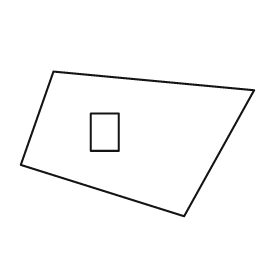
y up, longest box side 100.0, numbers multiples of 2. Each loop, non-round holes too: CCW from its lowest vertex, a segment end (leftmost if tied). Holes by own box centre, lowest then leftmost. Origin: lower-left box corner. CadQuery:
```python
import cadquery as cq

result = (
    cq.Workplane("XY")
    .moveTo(70.0, 0.0)
    .lineTo(100.0, 54.0)
    .lineTo(14.0, 62.0)
    .lineTo(0.0, 22.0)
    .close()
    .moveTo(30.0, 28.0)
    .lineTo(42.0, 28.0)
    .lineTo(42.0, 44.0)
    .lineTo(30.0, 44.0)
    .close()
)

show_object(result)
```